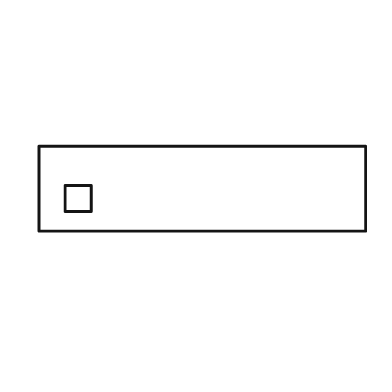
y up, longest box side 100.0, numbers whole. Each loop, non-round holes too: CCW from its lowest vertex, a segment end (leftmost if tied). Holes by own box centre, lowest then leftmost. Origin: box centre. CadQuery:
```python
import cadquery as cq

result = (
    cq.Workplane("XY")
    .moveTo(-50.0, -13.0)
    .lineTo(50.0, -13.0)
    .lineTo(50.0, 13.0)
    .lineTo(-50.0, 13.0)
    .close()
    .moveTo(-42.0, -7.0)
    .lineTo(-34.0, -7.0)
    .lineTo(-34.0, 1.0)
    .lineTo(-42.0, 1.0)
    .close()
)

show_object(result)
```